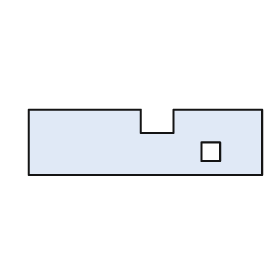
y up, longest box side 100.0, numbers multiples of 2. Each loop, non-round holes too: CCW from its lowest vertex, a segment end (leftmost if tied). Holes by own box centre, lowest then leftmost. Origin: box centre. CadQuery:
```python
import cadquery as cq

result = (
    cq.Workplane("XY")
    .moveTo(-50.0, -14.0)
    .lineTo(50.0, -14.0)
    .lineTo(50.0, 14.0)
    .lineTo(12.0, 14.0)
    .lineTo(12.0, 4.0)
    .lineTo(-2.0, 4.0)
    .lineTo(-2.0, 14.0)
    .lineTo(-50.0, 14.0)
    .close()
    .moveTo(24.0, -8.0)
    .lineTo(32.0, -8.0)
    .lineTo(32.0, 0.0)
    .lineTo(24.0, 0.0)
    .close()
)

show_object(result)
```